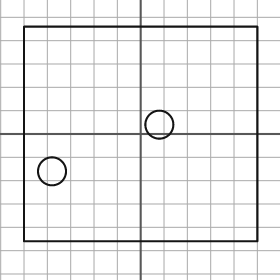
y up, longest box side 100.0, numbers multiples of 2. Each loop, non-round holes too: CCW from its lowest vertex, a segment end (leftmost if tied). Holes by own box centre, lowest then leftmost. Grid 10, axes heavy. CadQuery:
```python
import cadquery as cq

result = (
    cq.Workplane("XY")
    .moveTo(-50.0, -46.0)
    .lineTo(50.0, -46.0)
    .lineTo(50.0, 46.0)
    .lineTo(-50.0, 46.0)
    .close()
    .moveTo(-38.0, -16.0)
    .circle(6.0)
    .moveTo(8.0, 4.0)
    .circle(6.0)
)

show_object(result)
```